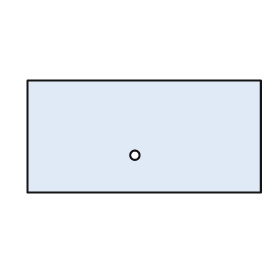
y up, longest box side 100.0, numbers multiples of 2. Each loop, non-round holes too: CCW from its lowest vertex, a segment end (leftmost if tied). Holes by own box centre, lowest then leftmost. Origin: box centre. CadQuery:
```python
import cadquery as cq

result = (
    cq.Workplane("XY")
    .moveTo(-50.0, -24.0)
    .lineTo(50.0, -24.0)
    .lineTo(50.0, 24.0)
    .lineTo(-50.0, 24.0)
    .close()
    .moveTo(-4.0, -8.0)
    .circle(2.0)
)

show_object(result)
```